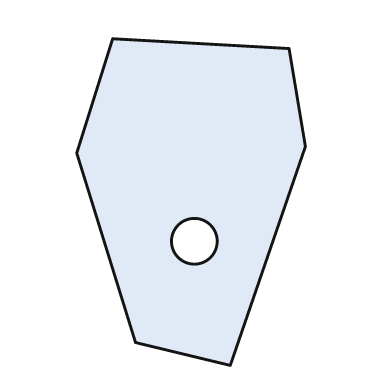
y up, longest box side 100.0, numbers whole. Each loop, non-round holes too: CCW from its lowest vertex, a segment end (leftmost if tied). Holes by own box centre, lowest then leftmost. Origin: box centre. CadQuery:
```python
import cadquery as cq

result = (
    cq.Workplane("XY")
    .moveTo(12.0, -50.0)
    .lineTo(35.0, 17.0)
    .lineTo(30.0, 47.0)
    .lineTo(-24.0, 50.0)
    .lineTo(-35.0, 15.0)
    .lineTo(-17.0, -43.0)
    .close()
    .moveTo(1.0, -12.0)
    .circle(7.0)
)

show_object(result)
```